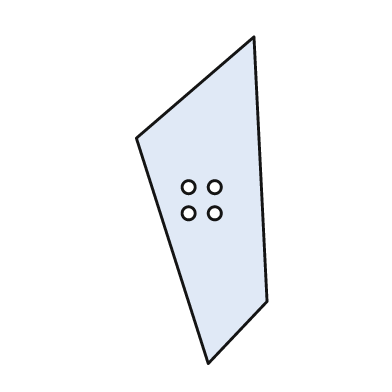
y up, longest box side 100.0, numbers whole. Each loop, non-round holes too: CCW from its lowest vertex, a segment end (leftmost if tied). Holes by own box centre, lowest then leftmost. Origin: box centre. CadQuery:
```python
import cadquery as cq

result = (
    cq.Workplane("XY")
    .moveTo(2.0, -50.0)
    .lineTo(20.0, -31.0)
    .lineTo(16.0, 50.0)
    .lineTo(-20.0, 19.0)
    .close()
    .moveTo(-4.0, -4.0)
    .circle(2.0)
    .moveTo(4.0, -4.0)
    .circle(2.0)
    .moveTo(-4.0, 4.0)
    .circle(2.0)
    .moveTo(4.0, 4.0)
    .circle(2.0)
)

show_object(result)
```